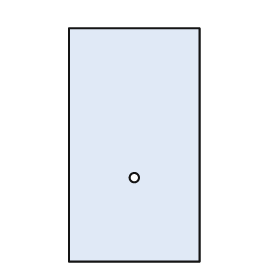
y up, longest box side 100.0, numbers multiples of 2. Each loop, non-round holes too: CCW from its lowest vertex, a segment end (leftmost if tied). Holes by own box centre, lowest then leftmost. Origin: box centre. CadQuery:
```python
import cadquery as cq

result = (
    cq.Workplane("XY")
    .moveTo(-28.0, -50.0)
    .lineTo(28.0, -50.0)
    .lineTo(28.0, 50.0)
    .lineTo(-28.0, 50.0)
    .close()
    .moveTo(0.0, -14.0)
    .circle(2.0)
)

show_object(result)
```